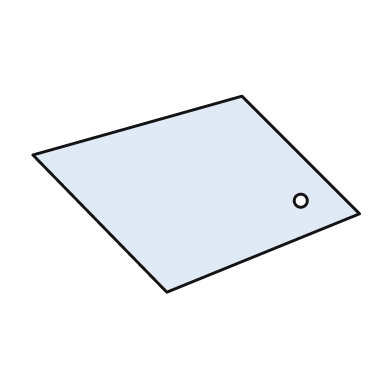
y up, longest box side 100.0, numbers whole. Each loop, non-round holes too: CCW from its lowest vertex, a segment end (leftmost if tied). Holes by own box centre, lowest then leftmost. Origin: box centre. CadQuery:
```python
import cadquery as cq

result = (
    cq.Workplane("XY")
    .moveTo(-9.0, -30.0)
    .lineTo(50.0, -6.0)
    .lineTo(14.0, 30.0)
    .lineTo(-50.0, 12.0)
    .close()
    .moveTo(32.0, -2.0)
    .circle(2.0)
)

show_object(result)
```